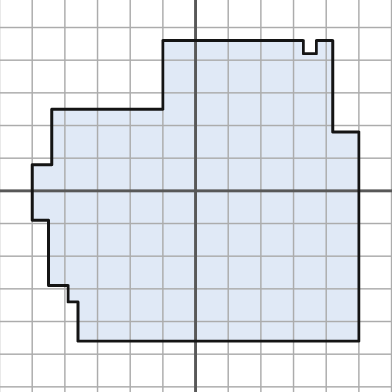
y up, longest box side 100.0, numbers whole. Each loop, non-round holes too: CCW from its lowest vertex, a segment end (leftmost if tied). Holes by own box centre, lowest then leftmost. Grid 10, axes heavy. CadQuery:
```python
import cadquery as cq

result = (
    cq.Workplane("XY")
    .moveTo(-36.0, -46.0)
    .lineTo(50.0, -46.0)
    .lineTo(50.0, 18.0)
    .lineTo(42.0, 18.0)
    .lineTo(42.0, 46.0)
    .lineTo(37.0, 46.0)
    .lineTo(37.0, 42.0)
    .lineTo(33.0, 42.0)
    .lineTo(33.0, 46.0)
    .lineTo(-10.0, 46.0)
    .lineTo(-10.0, 25.0)
    .lineTo(-44.0, 25.0)
    .lineTo(-44.0, 8.0)
    .lineTo(-50.0, 8.0)
    .lineTo(-50.0, -9.0)
    .lineTo(-45.0, -9.0)
    .lineTo(-45.0, -29.0)
    .lineTo(-39.0, -29.0)
    .lineTo(-39.0, -34.0)
    .lineTo(-36.0, -34.0)
    .close()
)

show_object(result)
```